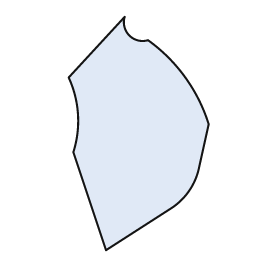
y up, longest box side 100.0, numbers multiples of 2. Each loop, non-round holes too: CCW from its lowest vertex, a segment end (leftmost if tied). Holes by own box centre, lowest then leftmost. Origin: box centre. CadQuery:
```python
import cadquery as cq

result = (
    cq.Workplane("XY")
    .moveTo(-14.0, -50.0)
    .lineTo(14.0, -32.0)
    .threePointArc((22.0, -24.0), (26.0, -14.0))
    .lineTo(30.0, 4.0)
    .threePointArc((20.0, 24.0), (4.0, 40.0))
    .threePointArc((-4.0, 42.0), (-6.0, 50.0))
    .lineTo(-30.0, 24.0)
    .threePointArc((-26.0, 8.0), (-28.0, -8.0))
    .close()
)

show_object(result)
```